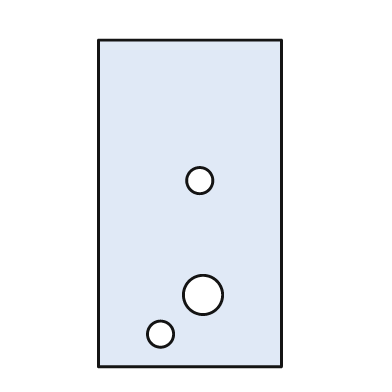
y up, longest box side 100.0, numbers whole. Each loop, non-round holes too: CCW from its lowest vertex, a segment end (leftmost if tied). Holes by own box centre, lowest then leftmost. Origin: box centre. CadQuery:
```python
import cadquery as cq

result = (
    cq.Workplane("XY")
    .moveTo(-28.0, -50.0)
    .lineTo(28.0, -50.0)
    .lineTo(28.0, 50.0)
    .lineTo(-28.0, 50.0)
    .close()
    .moveTo(-9.0, -40.0)
    .circle(4.0)
    .moveTo(4.0, -28.0)
    .circle(6.0)
    .moveTo(3.0, 7.0)
    .circle(4.0)
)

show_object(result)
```